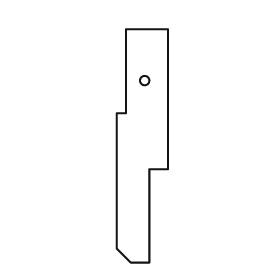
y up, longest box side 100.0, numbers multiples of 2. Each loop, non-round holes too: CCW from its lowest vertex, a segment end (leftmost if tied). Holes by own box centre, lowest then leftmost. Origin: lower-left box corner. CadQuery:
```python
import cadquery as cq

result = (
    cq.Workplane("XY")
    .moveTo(6.0, 0.0)
    .lineTo(14.0, 0.0)
    .lineTo(14.0, 40.0)
    .lineTo(22.0, 40.0)
    .lineTo(22.0, 100.0)
    .lineTo(4.0, 100.0)
    .lineTo(4.0, 64.0)
    .lineTo(0.0, 64.0)
    .lineTo(0.0, 6.0)
    .close()
    .moveTo(12.0, 78.0)
    .circle(2.0)
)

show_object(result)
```